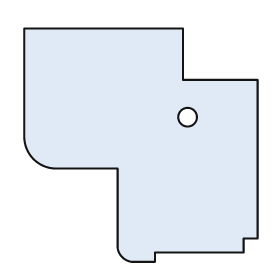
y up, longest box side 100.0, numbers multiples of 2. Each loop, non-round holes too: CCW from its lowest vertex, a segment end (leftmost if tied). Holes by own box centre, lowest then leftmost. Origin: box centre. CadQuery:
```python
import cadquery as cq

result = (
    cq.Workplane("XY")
    .moveTo(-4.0, -50.0)
    .lineTo(6.0, -50.0)
    .lineTo(6.0, -46.0)
    .lineTo(44.0, -46.0)
    .lineTo(44.0, -40.0)
    .lineTo(50.0, -40.0)
    .lineTo(50.0, 28.0)
    .lineTo(18.0, 28.0)
    .lineTo(18.0, 50.0)
    .lineTo(-50.0, 50.0)
    .lineTo(-50.0, 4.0)
    .threePointArc((-46.0, -6.0), (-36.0, -10.0))
    .lineTo(-10.0, -10.0)
    .lineTo(-10.0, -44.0)
    .threePointArc((-8.0, -48.0), (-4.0, -50.0))
    .close()
    .moveTo(20.0, 12.0)
    .circle(4.0)
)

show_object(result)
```